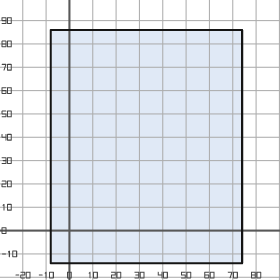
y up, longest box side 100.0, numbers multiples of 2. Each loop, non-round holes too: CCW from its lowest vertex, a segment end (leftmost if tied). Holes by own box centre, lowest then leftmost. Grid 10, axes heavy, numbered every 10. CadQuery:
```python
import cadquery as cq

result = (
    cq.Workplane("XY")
    .moveTo(-8.0, -14.0)
    .lineTo(74.0, -14.0)
    .lineTo(74.0, 86.0)
    .lineTo(-8.0, 86.0)
    .close()
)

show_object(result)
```